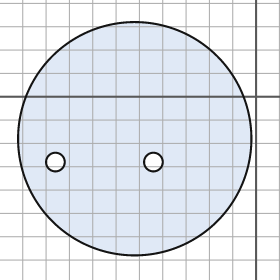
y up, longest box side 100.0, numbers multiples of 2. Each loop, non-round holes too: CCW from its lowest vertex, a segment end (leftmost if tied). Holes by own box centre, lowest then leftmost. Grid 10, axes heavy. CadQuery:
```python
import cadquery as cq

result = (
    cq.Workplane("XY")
    .moveTo(-52.0, -18.0)
    .circle(50.0)
    .moveTo(-86.0, -28.0)
    .circle(4.0)
    .moveTo(-44.0, -28.0)
    .circle(4.0)
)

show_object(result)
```